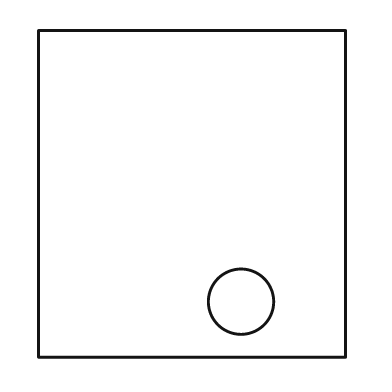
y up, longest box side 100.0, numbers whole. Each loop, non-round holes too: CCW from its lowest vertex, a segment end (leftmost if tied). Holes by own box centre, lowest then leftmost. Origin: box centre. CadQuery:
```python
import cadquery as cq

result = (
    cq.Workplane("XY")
    .moveTo(-47.0, -50.0)
    .lineTo(47.0, -50.0)
    .lineTo(47.0, 50.0)
    .lineTo(-47.0, 50.0)
    .close()
    .moveTo(15.0, -33.0)
    .circle(10.0)
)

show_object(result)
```